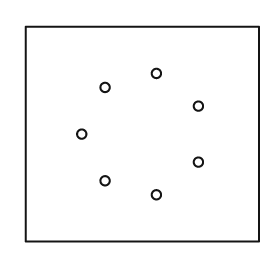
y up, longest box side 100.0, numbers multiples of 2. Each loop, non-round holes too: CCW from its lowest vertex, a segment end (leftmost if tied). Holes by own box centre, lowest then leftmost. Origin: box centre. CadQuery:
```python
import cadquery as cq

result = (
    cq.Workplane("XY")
    .moveTo(-50.0, -46.0)
    .lineTo(50.0, -46.0)
    .lineTo(50.0, 46.0)
    .lineTo(-50.0, 46.0)
    .close()
    .moveTo(6.0, -26.0)
    .circle(2.0)
    .moveTo(-16.0, -20.0)
    .circle(2.0)
    .moveTo(24.0, -12.0)
    .circle(2.0)
    .moveTo(-26.0, 0.0)
    .circle(2.0)
    .moveTo(24.0, 12.0)
    .circle(2.0)
    .moveTo(-16.0, 20.0)
    .circle(2.0)
    .moveTo(6.0, 26.0)
    .circle(2.0)
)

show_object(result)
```